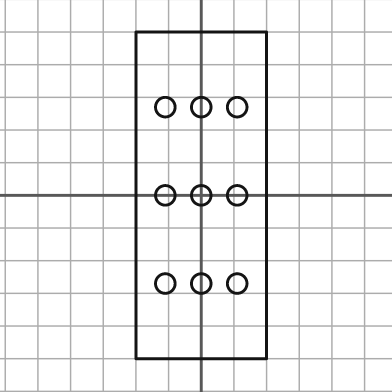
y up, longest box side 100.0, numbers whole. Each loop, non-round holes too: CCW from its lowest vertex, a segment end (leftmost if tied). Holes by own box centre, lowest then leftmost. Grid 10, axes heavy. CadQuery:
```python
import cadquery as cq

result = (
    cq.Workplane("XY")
    .moveTo(-20.0, -50.0)
    .lineTo(20.0, -50.0)
    .lineTo(20.0, 50.0)
    .lineTo(-20.0, 50.0)
    .close()
    .moveTo(-11.0, -27.0)
    .circle(3.0)
    .moveTo(0.0, -27.0)
    .circle(3.0)
    .moveTo(11.0, -27.0)
    .circle(3.0)
    .moveTo(-11.0, 0.0)
    .circle(3.0)
    .moveTo(0.0, 0.0)
    .circle(3.0)
    .moveTo(11.0, 0.0)
    .circle(3.0)
    .moveTo(-11.0, 27.0)
    .circle(3.0)
    .moveTo(0.0, 27.0)
    .circle(3.0)
    .moveTo(11.0, 27.0)
    .circle(3.0)
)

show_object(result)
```